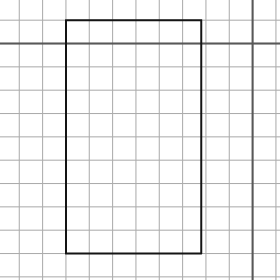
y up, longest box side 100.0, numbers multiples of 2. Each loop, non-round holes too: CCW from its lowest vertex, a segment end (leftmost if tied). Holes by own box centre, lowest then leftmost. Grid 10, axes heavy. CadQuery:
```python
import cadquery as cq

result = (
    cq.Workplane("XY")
    .moveTo(-80.0, -90.0)
    .lineTo(-22.0, -90.0)
    .lineTo(-22.0, 10.0)
    .lineTo(-80.0, 10.0)
    .close()
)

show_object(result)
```